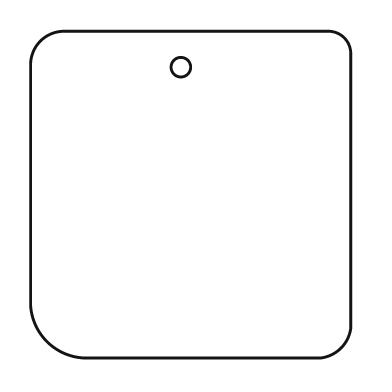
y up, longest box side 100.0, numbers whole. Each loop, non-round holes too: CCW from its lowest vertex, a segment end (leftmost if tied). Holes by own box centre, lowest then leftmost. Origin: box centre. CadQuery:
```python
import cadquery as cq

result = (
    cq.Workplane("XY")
    .moveTo(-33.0, -50.0)
    .lineTo(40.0, -50.0)
    .threePointArc((46.0, -47.0), (49.0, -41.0))
    .lineTo(49.0, 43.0)
    .threePointArc((47.0, 48.0), (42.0, 50.0))
    .lineTo(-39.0, 50.0)
    .threePointArc((-46.0, 47.0), (-49.0, 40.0))
    .lineTo(-49.0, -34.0)
    .threePointArc((-44.0, -45.0), (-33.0, -50.0))
    .close()
    .moveTo(-3.0, 39.0)
    .circle(3.0)
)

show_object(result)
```